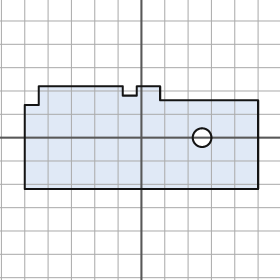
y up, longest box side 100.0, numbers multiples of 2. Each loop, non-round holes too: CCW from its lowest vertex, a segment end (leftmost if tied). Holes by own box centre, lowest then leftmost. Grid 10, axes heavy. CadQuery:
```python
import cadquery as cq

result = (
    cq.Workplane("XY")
    .moveTo(-50.0, -22.0)
    .lineTo(50.0, -22.0)
    .lineTo(50.0, 16.0)
    .lineTo(8.0, 16.0)
    .lineTo(8.0, 22.0)
    .lineTo(-2.0, 22.0)
    .lineTo(-2.0, 18.0)
    .lineTo(-8.0, 18.0)
    .lineTo(-8.0, 22.0)
    .lineTo(-44.0, 22.0)
    .lineTo(-44.0, 14.0)
    .lineTo(-50.0, 14.0)
    .close()
    .moveTo(26.0, 0.0)
    .circle(4.0)
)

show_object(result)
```